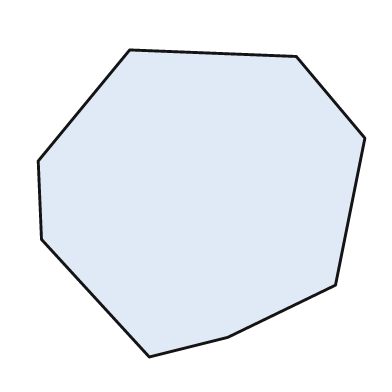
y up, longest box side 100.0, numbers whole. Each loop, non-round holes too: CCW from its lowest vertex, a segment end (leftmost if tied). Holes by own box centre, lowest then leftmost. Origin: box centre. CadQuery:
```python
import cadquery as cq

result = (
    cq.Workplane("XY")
    .moveTo(-16.0, -47.0)
    .lineTo(8.0, -41.0)
    .lineTo(41.0, -25.0)
    .lineTo(50.0, 20.0)
    .lineTo(29.0, 45.0)
    .lineTo(-22.0, 47.0)
    .lineTo(-50.0, 13.0)
    .lineTo(-49.0, -11.0)
    .close()
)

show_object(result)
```